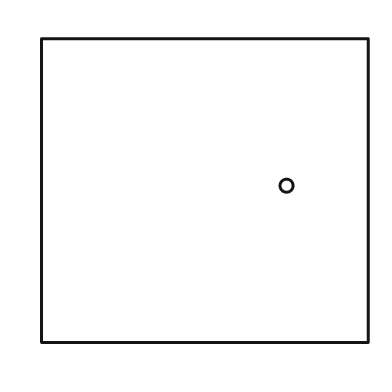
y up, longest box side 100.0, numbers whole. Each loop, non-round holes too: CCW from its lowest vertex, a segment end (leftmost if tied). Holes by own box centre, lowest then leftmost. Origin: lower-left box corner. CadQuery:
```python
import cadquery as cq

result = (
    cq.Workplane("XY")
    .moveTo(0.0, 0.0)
    .lineTo(100.0, 0.0)
    .lineTo(100.0, 93.0)
    .lineTo(0.0, 93.0)
    .close()
    .moveTo(75.0, 48.0)
    .circle(2.0)
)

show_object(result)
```